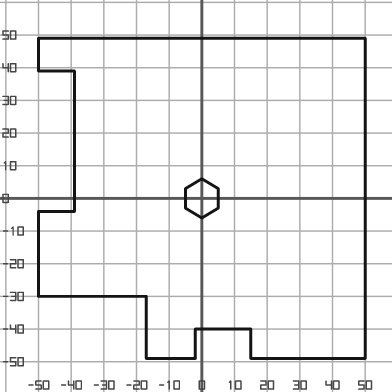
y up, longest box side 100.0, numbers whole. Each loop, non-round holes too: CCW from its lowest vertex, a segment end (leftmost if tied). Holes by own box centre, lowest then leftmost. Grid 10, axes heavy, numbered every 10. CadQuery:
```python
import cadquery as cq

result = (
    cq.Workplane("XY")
    .moveTo(-17.0, -49.0)
    .lineTo(-2.0, -49.0)
    .lineTo(-2.0, -40.0)
    .lineTo(15.0, -40.0)
    .lineTo(15.0, -49.0)
    .lineTo(50.0, -49.0)
    .lineTo(50.0, 49.0)
    .lineTo(-50.0, 49.0)
    .lineTo(-50.0, 39.0)
    .lineTo(-39.0, 39.0)
    .lineTo(-39.0, -4.0)
    .lineTo(-50.0, -4.0)
    .lineTo(-50.0, -30.0)
    .lineTo(-17.0, -30.0)
    .close()
    .moveTo(0.0, -6.0)
    .lineTo(5.0, -3.0)
    .lineTo(5.0, 3.0)
    .lineTo(0.0, 6.0)
    .lineTo(-5.0, 3.0)
    .lineTo(-5.0, -3.0)
    .close()
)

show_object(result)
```